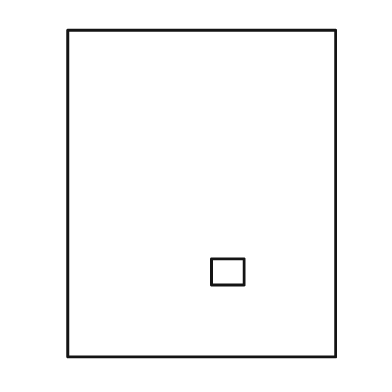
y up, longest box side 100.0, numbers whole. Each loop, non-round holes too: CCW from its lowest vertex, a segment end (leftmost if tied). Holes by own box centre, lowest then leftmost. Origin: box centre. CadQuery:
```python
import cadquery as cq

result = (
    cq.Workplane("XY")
    .moveTo(-41.0, -50.0)
    .lineTo(41.0, -50.0)
    .lineTo(41.0, 50.0)
    .lineTo(-41.0, 50.0)
    .close()
    .moveTo(3.0, -28.0)
    .lineTo(13.0, -28.0)
    .lineTo(13.0, -20.0)
    .lineTo(3.0, -20.0)
    .close()
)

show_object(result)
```